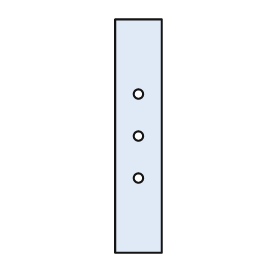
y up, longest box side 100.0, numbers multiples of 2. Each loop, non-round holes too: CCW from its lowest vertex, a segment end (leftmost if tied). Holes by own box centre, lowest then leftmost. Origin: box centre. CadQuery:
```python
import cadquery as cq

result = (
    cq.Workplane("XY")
    .moveTo(-10.0, -50.0)
    .lineTo(10.0, -50.0)
    .lineTo(10.0, 50.0)
    .lineTo(-10.0, 50.0)
    .close()
    .moveTo(0.0, -18.0)
    .circle(2.0)
    .moveTo(0.0, 0.0)
    .circle(2.0)
    .moveTo(0.0, 18.0)
    .circle(2.0)
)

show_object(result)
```